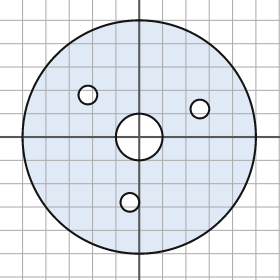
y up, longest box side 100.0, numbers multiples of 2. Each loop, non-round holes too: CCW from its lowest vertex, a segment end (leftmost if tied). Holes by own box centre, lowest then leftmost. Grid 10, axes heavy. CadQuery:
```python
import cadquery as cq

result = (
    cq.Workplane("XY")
    .moveTo(0.0, 0.0)
    .circle(50.0)
    .moveTo(-4.0, -28.0)
    .circle(4.0)
    .moveTo(0.0, 0.0)
    .circle(10.0)
    .moveTo(26.0, 12.0)
    .circle(4.0)
    .moveTo(-22.0, 18.0)
    .circle(4.0)
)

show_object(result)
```